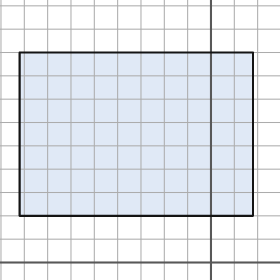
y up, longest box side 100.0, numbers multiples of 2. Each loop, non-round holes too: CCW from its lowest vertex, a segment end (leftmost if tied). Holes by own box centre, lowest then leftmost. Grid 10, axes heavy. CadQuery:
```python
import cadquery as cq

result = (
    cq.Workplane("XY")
    .moveTo(-82.0, 20.0)
    .lineTo(18.0, 20.0)
    .lineTo(18.0, 90.0)
    .lineTo(-82.0, 90.0)
    .close()
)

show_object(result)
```